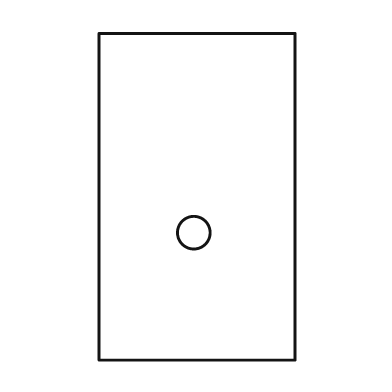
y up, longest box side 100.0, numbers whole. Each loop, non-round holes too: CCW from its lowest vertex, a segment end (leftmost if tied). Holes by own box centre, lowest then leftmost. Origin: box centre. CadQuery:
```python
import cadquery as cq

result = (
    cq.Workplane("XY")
    .moveTo(-30.0, -50.0)
    .lineTo(30.0, -50.0)
    .lineTo(30.0, 50.0)
    .lineTo(-30.0, 50.0)
    .close()
    .moveTo(-1.0, -11.0)
    .circle(5.0)
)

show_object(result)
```